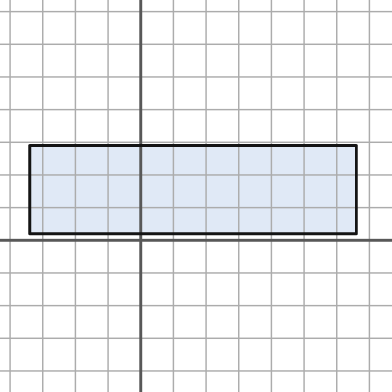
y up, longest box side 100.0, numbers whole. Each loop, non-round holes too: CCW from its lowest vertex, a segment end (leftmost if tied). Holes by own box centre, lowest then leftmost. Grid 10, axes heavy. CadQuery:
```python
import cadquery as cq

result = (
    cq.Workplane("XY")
    .moveTo(-34.0, 2.0)
    .lineTo(66.0, 2.0)
    .lineTo(66.0, 29.0)
    .lineTo(-34.0, 29.0)
    .close()
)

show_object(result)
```